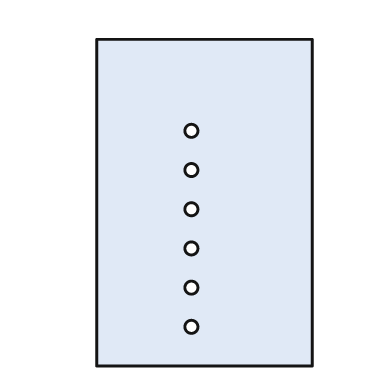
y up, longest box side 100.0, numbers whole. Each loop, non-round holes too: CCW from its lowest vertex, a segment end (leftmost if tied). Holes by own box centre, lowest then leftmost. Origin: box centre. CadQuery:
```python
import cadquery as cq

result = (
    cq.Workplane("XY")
    .moveTo(-33.0, -50.0)
    .lineTo(33.0, -50.0)
    .lineTo(33.0, 50.0)
    .lineTo(-33.0, 50.0)
    .close()
    .moveTo(-4.0, -38.0)
    .circle(2.0)
    .moveTo(-4.0, -26.0)
    .circle(2.0)
    .moveTo(-4.0, -14.0)
    .circle(2.0)
    .moveTo(-4.0, -2.0)
    .circle(2.0)
    .moveTo(-4.0, 10.0)
    .circle(2.0)
    .moveTo(-4.0, 22.0)
    .circle(2.0)
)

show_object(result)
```